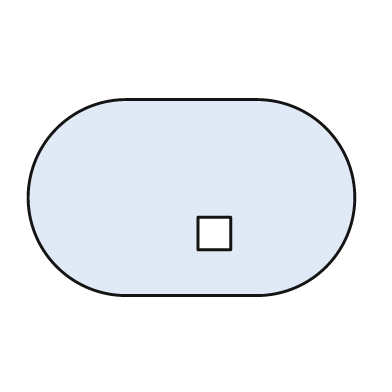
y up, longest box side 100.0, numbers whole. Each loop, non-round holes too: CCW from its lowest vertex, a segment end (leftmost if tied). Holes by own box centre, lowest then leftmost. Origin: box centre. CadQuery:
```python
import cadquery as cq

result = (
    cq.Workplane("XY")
    .moveTo(-20.0, -30.0)
    .lineTo(20.0, -30.0)
    .threePointArc((50.0, 0.0), (20.0, 30.0))
    .lineTo(-20.0, 30.0)
    .threePointArc((-50.0, 0.0), (-20.0, -30.0))
    .close()
    .moveTo(2.0, -16.0)
    .lineTo(12.0, -16.0)
    .lineTo(12.0, -6.0)
    .lineTo(2.0, -6.0)
    .close()
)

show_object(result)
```